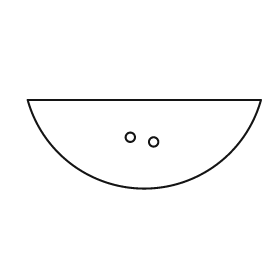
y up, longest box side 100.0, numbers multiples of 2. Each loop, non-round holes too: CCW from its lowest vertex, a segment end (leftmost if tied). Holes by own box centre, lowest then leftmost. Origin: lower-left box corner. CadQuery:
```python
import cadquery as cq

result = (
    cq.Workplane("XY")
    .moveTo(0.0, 38.0)
    .threePointArc((50.0, 0.0), (100.0, 38.0))
    .close()
    .moveTo(54.0, 20.0)
    .circle(2.0)
    .moveTo(44.0, 22.0)
    .circle(2.0)
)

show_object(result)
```